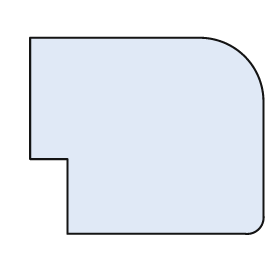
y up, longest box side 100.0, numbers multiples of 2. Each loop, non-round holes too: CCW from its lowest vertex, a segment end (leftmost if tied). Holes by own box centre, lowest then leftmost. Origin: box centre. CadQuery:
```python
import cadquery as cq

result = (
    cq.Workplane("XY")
    .moveTo(-34.0, -42.0)
    .lineTo(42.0, -42.0)
    .threePointArc((48.0, -40.0), (50.0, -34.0))
    .lineTo(50.0, 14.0)
    .threePointArc((42.0, 34.0), (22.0, 42.0))
    .lineTo(-50.0, 42.0)
    .lineTo(-50.0, -10.0)
    .lineTo(-34.0, -10.0)
    .close()
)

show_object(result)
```